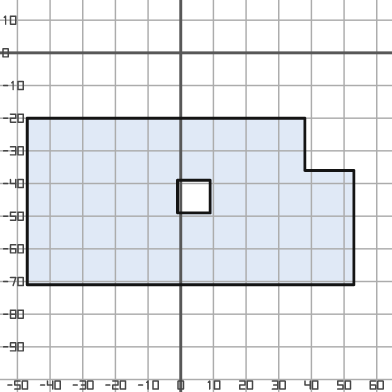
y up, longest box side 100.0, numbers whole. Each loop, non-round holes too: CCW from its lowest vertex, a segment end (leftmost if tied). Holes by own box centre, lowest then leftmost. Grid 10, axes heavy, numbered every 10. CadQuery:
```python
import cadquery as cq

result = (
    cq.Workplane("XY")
    .moveTo(-47.0, -71.0)
    .lineTo(53.0, -71.0)
    .lineTo(53.0, -36.0)
    .lineTo(38.0, -36.0)
    .lineTo(38.0, -20.0)
    .lineTo(-47.0, -20.0)
    .close()
    .moveTo(-1.0, -49.0)
    .lineTo(9.0, -49.0)
    .lineTo(9.0, -39.0)
    .lineTo(-1.0, -39.0)
    .close()
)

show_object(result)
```